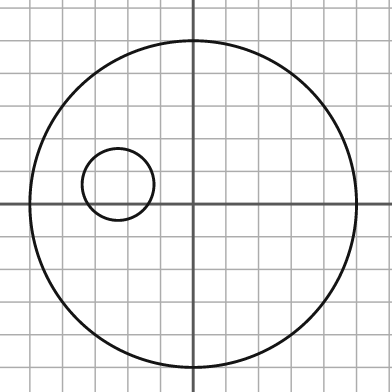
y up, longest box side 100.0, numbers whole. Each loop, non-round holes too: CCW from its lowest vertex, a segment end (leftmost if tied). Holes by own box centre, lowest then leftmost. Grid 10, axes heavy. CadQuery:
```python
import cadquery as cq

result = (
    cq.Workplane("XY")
    .moveTo(0.0, 0.0)
    .circle(50.0)
    .moveTo(-23.0, 6.0)
    .circle(11.0)
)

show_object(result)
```